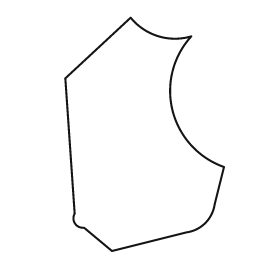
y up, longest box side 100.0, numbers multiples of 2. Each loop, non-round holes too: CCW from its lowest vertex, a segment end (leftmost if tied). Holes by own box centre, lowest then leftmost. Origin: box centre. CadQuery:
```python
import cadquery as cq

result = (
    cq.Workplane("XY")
    .moveTo(-14.0, -50.0)
    .lineTo(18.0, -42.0)
    .threePointArc((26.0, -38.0), (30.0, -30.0))
    .lineTo(34.0, -14.0)
    .threePointArc((12.0, 10.0), (20.0, 42.0))
    .threePointArc((6.0, 42.0), (-6.0, 50.0))
    .lineTo(-34.0, 24.0)
    .lineTo(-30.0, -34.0)
    .threePointArc((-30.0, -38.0), (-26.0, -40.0))
    .close()
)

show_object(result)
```